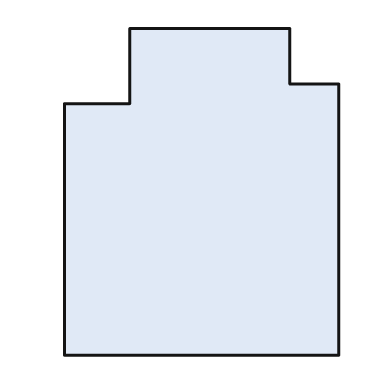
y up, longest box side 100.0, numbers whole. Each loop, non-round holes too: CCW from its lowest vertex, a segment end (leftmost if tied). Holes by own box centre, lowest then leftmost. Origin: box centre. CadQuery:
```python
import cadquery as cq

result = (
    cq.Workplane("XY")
    .moveTo(-42.0, -50.0)
    .lineTo(42.0, -50.0)
    .lineTo(42.0, 33.0)
    .lineTo(27.0, 33.0)
    .lineTo(27.0, 50.0)
    .lineTo(-22.0, 50.0)
    .lineTo(-22.0, 27.0)
    .lineTo(-42.0, 27.0)
    .close()
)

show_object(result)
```